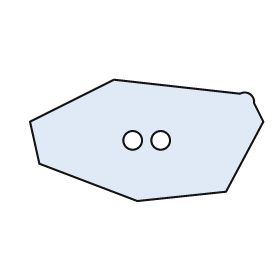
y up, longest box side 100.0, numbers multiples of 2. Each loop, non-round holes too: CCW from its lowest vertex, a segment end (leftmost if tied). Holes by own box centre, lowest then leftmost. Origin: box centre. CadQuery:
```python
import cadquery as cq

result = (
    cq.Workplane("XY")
    .moveTo(-4.0, -26.0)
    .lineTo(34.0, -22.0)
    .lineTo(50.0, 8.0)
    .lineTo(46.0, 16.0)
    .threePointArc((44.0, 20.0), (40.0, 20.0))
    .lineTo(-14.0, 26.0)
    .lineTo(-50.0, 8.0)
    .lineTo(-46.0, -10.0)
    .close()
    .moveTo(-6.0, 0.0)
    .circle(4.0)
    .moveTo(6.0, 0.0)
    .circle(4.0)
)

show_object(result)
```